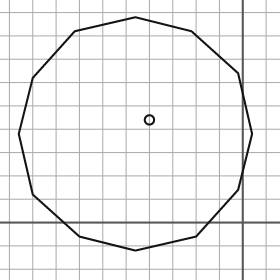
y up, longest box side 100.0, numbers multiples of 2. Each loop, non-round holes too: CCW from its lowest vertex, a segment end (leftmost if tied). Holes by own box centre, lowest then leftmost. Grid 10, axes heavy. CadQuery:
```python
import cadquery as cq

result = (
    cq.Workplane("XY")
    .moveTo(-46.0, -12.0)
    .lineTo(-20.0, -6.0)
    .lineTo(-2.0, 14.0)
    .lineTo(4.0, 38.0)
    .lineTo(-2.0, 64.0)
    .lineTo(-22.0, 82.0)
    .lineTo(-46.0, 88.0)
    .lineTo(-72.0, 82.0)
    .lineTo(-90.0, 62.0)
    .lineTo(-96.0, 38.0)
    .lineTo(-90.0, 12.0)
    .lineTo(-70.0, -6.0)
    .close()
    .moveTo(-40.0, 44.0)
    .circle(2.0)
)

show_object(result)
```